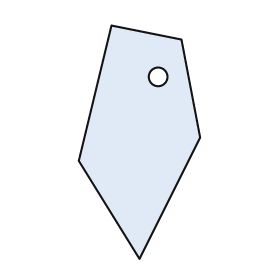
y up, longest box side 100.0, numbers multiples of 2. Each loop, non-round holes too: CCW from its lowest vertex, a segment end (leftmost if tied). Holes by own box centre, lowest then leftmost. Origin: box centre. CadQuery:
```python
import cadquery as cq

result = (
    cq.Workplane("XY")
    .moveTo(0.0, -50.0)
    .lineTo(26.0, 2.0)
    .lineTo(18.0, 44.0)
    .lineTo(-12.0, 50.0)
    .lineTo(-26.0, -8.0)
    .close()
    .moveTo(8.0, 28.0)
    .circle(4.0)
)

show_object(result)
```